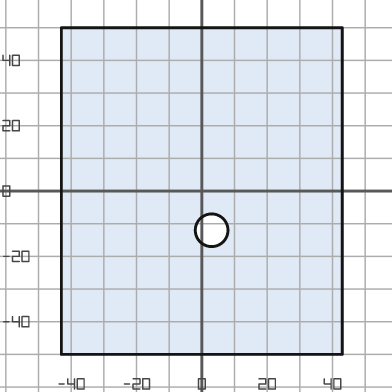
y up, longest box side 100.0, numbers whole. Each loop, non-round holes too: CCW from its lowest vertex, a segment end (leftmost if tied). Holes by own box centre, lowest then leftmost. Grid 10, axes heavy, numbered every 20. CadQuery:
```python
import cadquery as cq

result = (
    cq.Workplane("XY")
    .moveTo(-43.0, -50.0)
    .lineTo(43.0, -50.0)
    .lineTo(43.0, 50.0)
    .lineTo(-43.0, 50.0)
    .close()
    .moveTo(3.0, -12.0)
    .circle(5.0)
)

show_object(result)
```